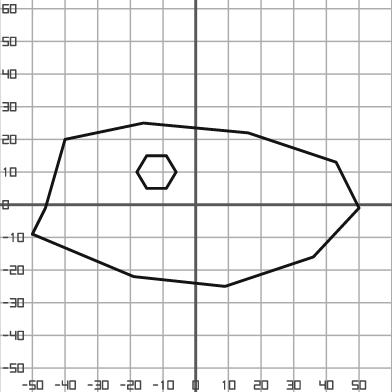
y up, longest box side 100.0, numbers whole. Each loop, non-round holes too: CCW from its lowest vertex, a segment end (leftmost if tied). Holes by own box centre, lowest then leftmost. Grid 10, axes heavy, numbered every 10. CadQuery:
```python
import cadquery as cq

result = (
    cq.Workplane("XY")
    .moveTo(9.0, -25.0)
    .lineTo(36.0, -16.0)
    .lineTo(50.0, -1.0)
    .lineTo(43.0, 13.0)
    .lineTo(16.0, 22.0)
    .lineTo(-16.0, 25.0)
    .lineTo(-40.0, 20.0)
    .lineTo(-46.0, -1.0)
    .lineTo(-50.0, -9.0)
    .lineTo(-19.0, -22.0)
    .close()
    .moveTo(-15.0, 5.0)
    .lineTo(-9.0, 5.0)
    .lineTo(-6.0, 10.0)
    .lineTo(-9.0, 15.0)
    .lineTo(-15.0, 15.0)
    .lineTo(-18.0, 10.0)
    .close()
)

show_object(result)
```